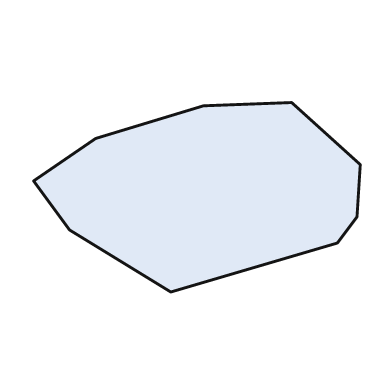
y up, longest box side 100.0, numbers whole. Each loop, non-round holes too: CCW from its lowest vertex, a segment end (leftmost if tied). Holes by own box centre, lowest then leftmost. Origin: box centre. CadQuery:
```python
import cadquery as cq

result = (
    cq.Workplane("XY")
    .moveTo(-8.0, -29.0)
    .lineTo(43.0, -14.0)
    .lineTo(49.0, -6.0)
    .lineTo(50.0, 10.0)
    .lineTo(29.0, 29.0)
    .lineTo(2.0, 28.0)
    .lineTo(-31.0, 18.0)
    .lineTo(-50.0, 5.0)
    .lineTo(-39.0, -10.0)
    .close()
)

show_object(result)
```